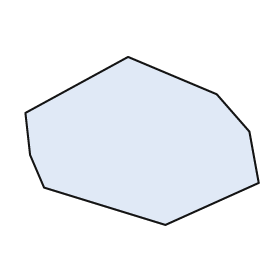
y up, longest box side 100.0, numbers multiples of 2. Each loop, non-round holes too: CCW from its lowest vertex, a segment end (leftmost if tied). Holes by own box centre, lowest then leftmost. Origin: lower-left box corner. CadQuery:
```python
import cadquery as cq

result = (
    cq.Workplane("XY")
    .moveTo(60.0, 0.0)
    .lineTo(100.0, 18.0)
    .lineTo(96.0, 40.0)
    .lineTo(82.0, 56.0)
    .lineTo(44.0, 72.0)
    .lineTo(0.0, 48.0)
    .lineTo(2.0, 30.0)
    .lineTo(8.0, 16.0)
    .close()
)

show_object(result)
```